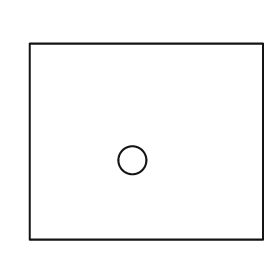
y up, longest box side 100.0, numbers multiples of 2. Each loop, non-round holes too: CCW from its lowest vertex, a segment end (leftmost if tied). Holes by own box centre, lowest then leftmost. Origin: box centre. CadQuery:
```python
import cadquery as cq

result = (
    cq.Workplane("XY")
    .moveTo(-50.0, -42.0)
    .lineTo(50.0, -42.0)
    .lineTo(50.0, 42.0)
    .lineTo(-50.0, 42.0)
    .close()
    .moveTo(-6.0, -8.0)
    .circle(6.0)
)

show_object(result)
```